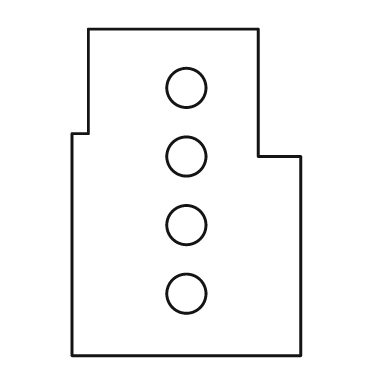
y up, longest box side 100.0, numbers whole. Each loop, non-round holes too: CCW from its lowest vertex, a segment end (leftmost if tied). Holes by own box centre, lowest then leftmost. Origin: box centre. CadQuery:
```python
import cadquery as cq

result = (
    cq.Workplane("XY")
    .moveTo(-35.0, -50.0)
    .lineTo(35.0, -50.0)
    .lineTo(35.0, 11.0)
    .lineTo(22.0, 11.0)
    .lineTo(22.0, 50.0)
    .lineTo(-30.0, 50.0)
    .lineTo(-30.0, 18.0)
    .lineTo(-35.0, 18.0)
    .close()
    .moveTo(0.0, -31.0)
    .circle(6.0)
    .moveTo(0.0, -10.0)
    .circle(6.0)
    .moveTo(0.0, 11.0)
    .circle(6.0)
    .moveTo(0.0, 32.0)
    .circle(6.0)
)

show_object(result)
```